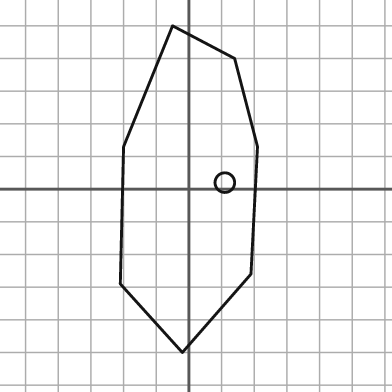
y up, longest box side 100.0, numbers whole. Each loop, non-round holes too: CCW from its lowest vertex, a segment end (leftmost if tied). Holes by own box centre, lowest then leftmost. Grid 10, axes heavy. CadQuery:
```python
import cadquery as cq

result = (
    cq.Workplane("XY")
    .moveTo(-2.0, -50.0)
    .lineTo(19.0, -26.0)
    .lineTo(21.0, 13.0)
    .lineTo(14.0, 40.0)
    .lineTo(-5.0, 50.0)
    .lineTo(-20.0, 13.0)
    .lineTo(-21.0, -29.0)
    .close()
    .moveTo(11.0, 2.0)
    .circle(3.0)
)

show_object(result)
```